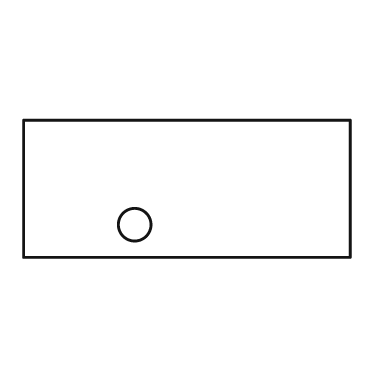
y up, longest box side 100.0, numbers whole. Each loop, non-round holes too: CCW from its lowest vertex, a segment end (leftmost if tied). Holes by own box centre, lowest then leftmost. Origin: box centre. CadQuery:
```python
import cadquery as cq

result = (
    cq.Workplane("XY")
    .moveTo(-50.0, -21.0)
    .lineTo(50.0, -21.0)
    .lineTo(50.0, 21.0)
    .lineTo(-50.0, 21.0)
    .close()
    .moveTo(-16.0, -11.0)
    .circle(5.0)
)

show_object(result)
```